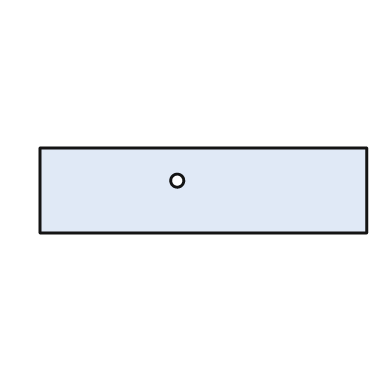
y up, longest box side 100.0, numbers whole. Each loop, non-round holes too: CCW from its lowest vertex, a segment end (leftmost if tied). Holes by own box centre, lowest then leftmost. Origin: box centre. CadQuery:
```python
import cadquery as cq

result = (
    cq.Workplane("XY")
    .moveTo(-50.0, -13.0)
    .lineTo(50.0, -13.0)
    .lineTo(50.0, 13.0)
    .lineTo(-50.0, 13.0)
    .close()
    .moveTo(-8.0, 3.0)
    .circle(2.0)
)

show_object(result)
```